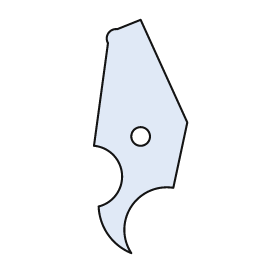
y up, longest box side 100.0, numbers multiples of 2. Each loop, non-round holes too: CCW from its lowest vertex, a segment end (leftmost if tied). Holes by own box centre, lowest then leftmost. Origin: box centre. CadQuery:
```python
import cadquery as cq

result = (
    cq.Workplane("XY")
    .moveTo(-4.0, -50.0)
    .threePointArc((-4.0, -30.0), (14.0, -22.0))
    .lineTo(20.0, 6.0)
    .lineTo(0.0, 50.0)
    .lineTo(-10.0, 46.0)
    .threePointArc((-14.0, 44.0), (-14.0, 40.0))
    .lineTo(-20.0, -4.0)
    .threePointArc((-8.0, -16.0), (-18.0, -30.0))
    .threePointArc((-14.0, -42.0), (-4.0, -50.0))
    .close()
    .moveTo(0.0, 0.0)
    .circle(4.0)
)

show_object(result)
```